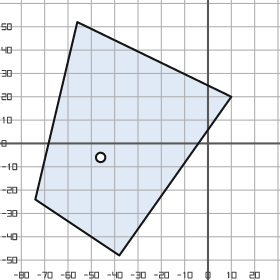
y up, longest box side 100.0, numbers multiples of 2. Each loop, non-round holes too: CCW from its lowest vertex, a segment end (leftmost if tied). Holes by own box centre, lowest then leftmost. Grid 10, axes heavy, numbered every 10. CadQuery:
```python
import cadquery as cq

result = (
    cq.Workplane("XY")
    .moveTo(-38.0, -48.0)
    .lineTo(10.0, 20.0)
    .lineTo(-56.0, 52.0)
    .lineTo(-74.0, -24.0)
    .close()
    .moveTo(-46.0, -6.0)
    .circle(2.0)
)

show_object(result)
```